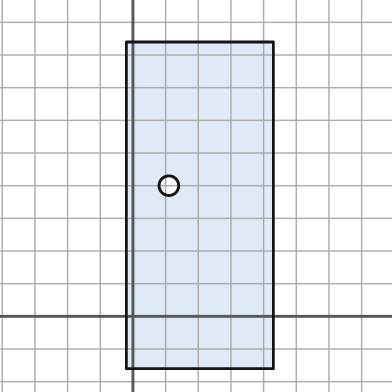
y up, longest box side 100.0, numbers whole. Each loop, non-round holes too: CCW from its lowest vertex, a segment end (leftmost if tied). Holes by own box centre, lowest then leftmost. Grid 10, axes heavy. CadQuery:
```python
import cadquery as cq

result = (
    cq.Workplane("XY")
    .moveTo(-2.0, -16.0)
    .lineTo(43.0, -16.0)
    .lineTo(43.0, 84.0)
    .lineTo(-2.0, 84.0)
    .close()
    .moveTo(11.0, 40.0)
    .circle(3.0)
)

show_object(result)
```